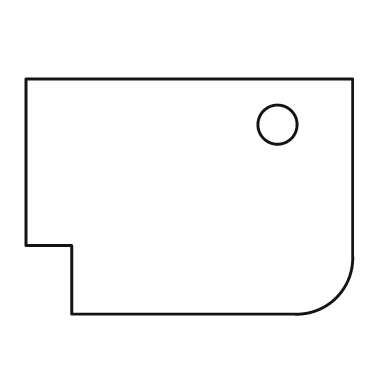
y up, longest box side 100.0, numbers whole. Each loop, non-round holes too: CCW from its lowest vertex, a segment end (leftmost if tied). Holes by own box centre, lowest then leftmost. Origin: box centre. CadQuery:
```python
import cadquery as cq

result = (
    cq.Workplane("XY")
    .moveTo(-36.0, -36.0)
    .lineTo(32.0, -36.0)
    .threePointArc((45.0, -31.0), (50.0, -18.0))
    .lineTo(50.0, 36.0)
    .lineTo(-50.0, 36.0)
    .lineTo(-50.0, -15.0)
    .lineTo(-36.0, -15.0)
    .close()
    .moveTo(27.0, 22.0)
    .circle(6.0)
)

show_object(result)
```